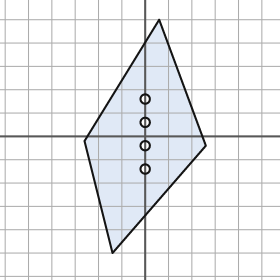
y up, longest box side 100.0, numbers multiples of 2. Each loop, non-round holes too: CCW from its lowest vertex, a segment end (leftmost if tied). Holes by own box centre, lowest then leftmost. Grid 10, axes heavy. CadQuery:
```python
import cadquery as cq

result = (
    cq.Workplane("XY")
    .moveTo(-14.0, -50.0)
    .lineTo(26.0, -4.0)
    .lineTo(6.0, 50.0)
    .lineTo(-26.0, -2.0)
    .close()
    .moveTo(0.0, -14.0)
    .circle(2.0)
    .moveTo(0.0, -4.0)
    .circle(2.0)
    .moveTo(0.0, 6.0)
    .circle(2.0)
    .moveTo(0.0, 16.0)
    .circle(2.0)
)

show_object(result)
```